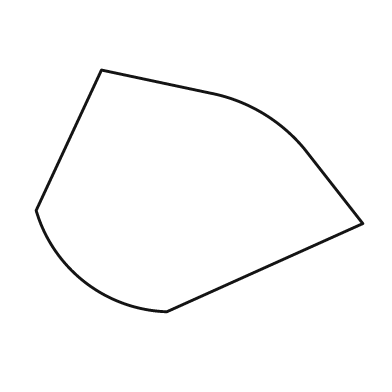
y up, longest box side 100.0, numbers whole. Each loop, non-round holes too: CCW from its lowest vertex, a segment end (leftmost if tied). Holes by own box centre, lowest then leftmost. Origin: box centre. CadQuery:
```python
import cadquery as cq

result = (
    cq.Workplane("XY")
    .moveTo(-10.0, -37.0)
    .lineTo(50.0, -10.0)
    .lineTo(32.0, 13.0)
    .threePointArc((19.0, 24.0), (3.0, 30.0))
    .lineTo(-30.0, 37.0)
    .lineTo(-50.0, -6.0)
    .threePointArc((-35.0, -28.0), (-10.0, -37.0))
    .close()
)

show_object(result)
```